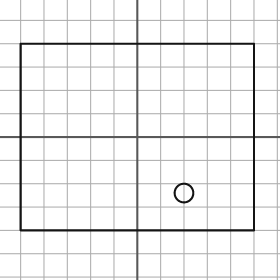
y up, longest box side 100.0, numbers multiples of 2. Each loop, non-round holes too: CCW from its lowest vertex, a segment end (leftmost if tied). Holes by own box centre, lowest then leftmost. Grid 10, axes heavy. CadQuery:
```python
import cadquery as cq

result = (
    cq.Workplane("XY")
    .moveTo(-50.0, -40.0)
    .lineTo(50.0, -40.0)
    .lineTo(50.0, 40.0)
    .lineTo(-50.0, 40.0)
    .close()
    .moveTo(20.0, -24.0)
    .circle(4.0)
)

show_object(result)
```